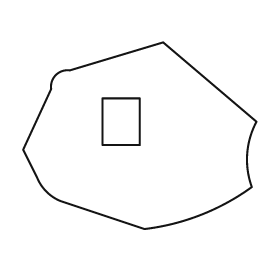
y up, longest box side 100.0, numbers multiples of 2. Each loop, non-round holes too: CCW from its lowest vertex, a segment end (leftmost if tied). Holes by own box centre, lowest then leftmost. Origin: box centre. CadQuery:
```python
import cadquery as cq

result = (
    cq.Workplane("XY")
    .moveTo(2.0, -40.0)
    .threePointArc((26.0, -34.0), (48.0, -22.0))
    .threePointArc((46.0, -8.0), (50.0, 6.0))
    .lineTo(10.0, 40.0)
    .lineTo(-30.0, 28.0)
    .threePointArc((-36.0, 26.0), (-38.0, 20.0))
    .lineTo(-50.0, -6.0)
    .lineTo(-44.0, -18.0)
    .threePointArc((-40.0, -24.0), (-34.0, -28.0))
    .close()
    .moveTo(-16.0, -4.0)
    .lineTo(0.0, -4.0)
    .lineTo(0.0, 16.0)
    .lineTo(-16.0, 16.0)
    .close()
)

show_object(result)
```